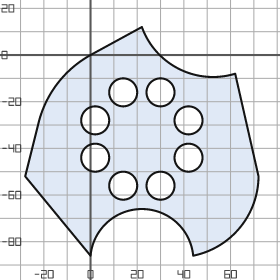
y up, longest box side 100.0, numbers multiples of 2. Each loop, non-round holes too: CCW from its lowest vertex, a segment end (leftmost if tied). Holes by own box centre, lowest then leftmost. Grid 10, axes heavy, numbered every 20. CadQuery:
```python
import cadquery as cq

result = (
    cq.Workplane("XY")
    .moveTo(0.0, -86.0)
    .threePointArc((22.0, -66.0), (44.0, -86.0))
    .threePointArc((64.0, -74.0), (72.0, -52.0))
    .lineTo(62.0, -8.0)
    .threePointArc((38.0, -6.0), (22.0, 12.0))
    .lineTo(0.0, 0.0)
    .threePointArc((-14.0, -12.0), (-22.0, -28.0))
    .lineTo(-28.0, -52.0)
    .close()
    .moveTo(14.0, -56.0)
    .circle(6.0)
    .moveTo(30.0, -56.0)
    .circle(6.0)
    .moveTo(2.0, -44.0)
    .circle(6.0)
    .moveTo(42.0, -44.0)
    .circle(6.0)
    .moveTo(2.0, -28.0)
    .circle(6.0)
    .moveTo(42.0, -28.0)
    .circle(6.0)
    .moveTo(14.0, -16.0)
    .circle(6.0)
    .moveTo(30.0, -16.0)
    .circle(6.0)
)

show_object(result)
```